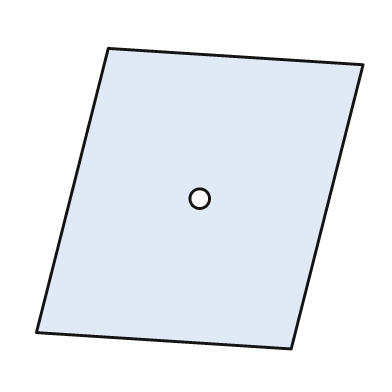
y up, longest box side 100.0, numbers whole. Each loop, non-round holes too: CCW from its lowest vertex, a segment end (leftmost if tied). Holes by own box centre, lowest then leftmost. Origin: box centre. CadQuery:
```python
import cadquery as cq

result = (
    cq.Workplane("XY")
    .moveTo(28.0, -46.0)
    .lineTo(50.0, 41.0)
    .lineTo(-28.0, 46.0)
    .lineTo(-50.0, -41.0)
    .close()
    .moveTo(0.0, 0.0)
    .circle(3.0)
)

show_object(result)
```